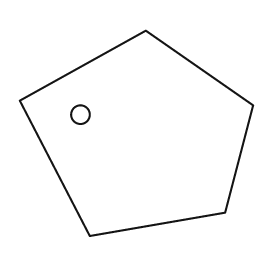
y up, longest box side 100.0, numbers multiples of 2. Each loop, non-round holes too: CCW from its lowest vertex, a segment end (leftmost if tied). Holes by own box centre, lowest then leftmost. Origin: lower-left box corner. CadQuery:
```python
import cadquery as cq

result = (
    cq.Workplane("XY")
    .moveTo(30.0, 0.0)
    .lineTo(88.0, 10.0)
    .lineTo(100.0, 56.0)
    .lineTo(54.0, 88.0)
    .lineTo(0.0, 58.0)
    .close()
    .moveTo(26.0, 52.0)
    .circle(4.0)
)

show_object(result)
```